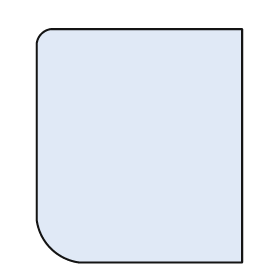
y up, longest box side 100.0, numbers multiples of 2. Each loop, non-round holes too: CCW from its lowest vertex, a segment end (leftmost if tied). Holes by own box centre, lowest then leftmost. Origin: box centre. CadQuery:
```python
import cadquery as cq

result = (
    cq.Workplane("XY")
    .moveTo(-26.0, -50.0)
    .lineTo(44.0, -50.0)
    .lineTo(44.0, 50.0)
    .lineTo(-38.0, 50.0)
    .threePointArc((-42.0, 48.0), (-44.0, 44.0))
    .lineTo(-44.0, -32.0)
    .threePointArc((-38.0, -44.0), (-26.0, -50.0))
    .close()
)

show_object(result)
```